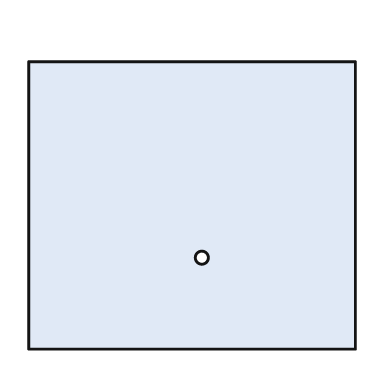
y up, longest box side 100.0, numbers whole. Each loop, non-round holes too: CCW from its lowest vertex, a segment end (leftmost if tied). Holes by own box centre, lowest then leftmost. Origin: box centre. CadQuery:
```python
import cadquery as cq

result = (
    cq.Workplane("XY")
    .moveTo(-50.0, -44.0)
    .lineTo(50.0, -44.0)
    .lineTo(50.0, 44.0)
    .lineTo(-50.0, 44.0)
    .close()
    .moveTo(3.0, -16.0)
    .circle(2.0)
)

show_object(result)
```